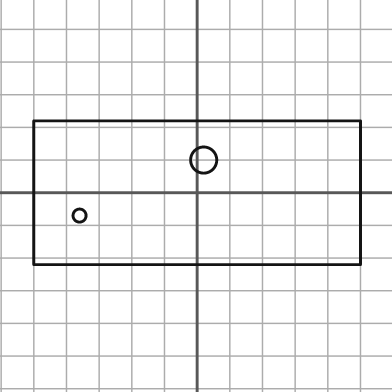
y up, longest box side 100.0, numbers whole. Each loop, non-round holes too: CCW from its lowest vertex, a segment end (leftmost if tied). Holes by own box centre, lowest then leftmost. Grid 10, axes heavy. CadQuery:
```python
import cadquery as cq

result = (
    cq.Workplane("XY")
    .moveTo(-50.0, -22.0)
    .lineTo(50.0, -22.0)
    .lineTo(50.0, 22.0)
    .lineTo(-50.0, 22.0)
    .close()
    .moveTo(-36.0, -7.0)
    .circle(2.0)
    .moveTo(2.0, 10.0)
    .circle(4.0)
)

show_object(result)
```